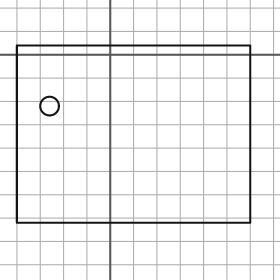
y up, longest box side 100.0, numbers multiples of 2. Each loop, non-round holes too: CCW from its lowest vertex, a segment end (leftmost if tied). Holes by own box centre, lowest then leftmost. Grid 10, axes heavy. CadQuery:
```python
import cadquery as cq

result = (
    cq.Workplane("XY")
    .moveTo(-40.0, -72.0)
    .lineTo(60.0, -72.0)
    .lineTo(60.0, 4.0)
    .lineTo(-40.0, 4.0)
    .close()
    .moveTo(-26.0, -22.0)
    .circle(4.0)
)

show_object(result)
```